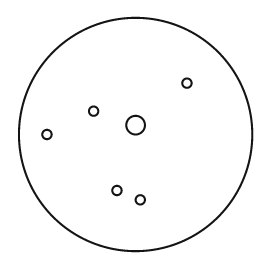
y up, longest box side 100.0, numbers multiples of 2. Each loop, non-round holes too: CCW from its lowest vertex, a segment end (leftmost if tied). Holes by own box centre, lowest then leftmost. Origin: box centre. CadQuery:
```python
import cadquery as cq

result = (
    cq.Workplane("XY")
    .moveTo(0.0, 0.0)
    .circle(50.0)
    .moveTo(2.0, -28.0)
    .circle(2.0)
    .moveTo(-8.0, -24.0)
    .circle(2.0)
    .moveTo(-38.0, 0.0)
    .circle(2.0)
    .moveTo(0.0, 4.0)
    .circle(4.0)
    .moveTo(-18.0, 10.0)
    .circle(2.0)
    .moveTo(22.0, 22.0)
    .circle(2.0)
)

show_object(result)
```